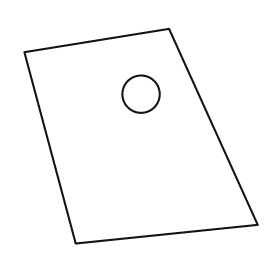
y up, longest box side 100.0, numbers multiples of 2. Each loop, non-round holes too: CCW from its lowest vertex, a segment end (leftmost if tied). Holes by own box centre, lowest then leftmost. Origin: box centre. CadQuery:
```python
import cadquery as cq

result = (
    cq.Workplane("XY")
    .moveTo(-28.0, -46.0)
    .lineTo(50.0, -38.0)
    .lineTo(12.0, 46.0)
    .lineTo(-50.0, 36.0)
    .close()
    .moveTo(0.0, 18.0)
    .circle(8.0)
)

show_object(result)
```